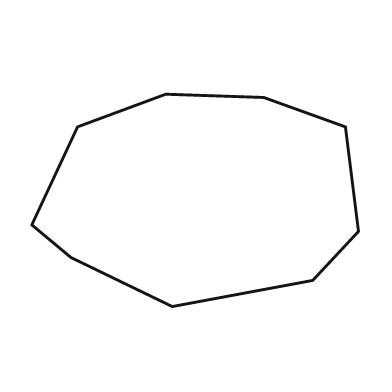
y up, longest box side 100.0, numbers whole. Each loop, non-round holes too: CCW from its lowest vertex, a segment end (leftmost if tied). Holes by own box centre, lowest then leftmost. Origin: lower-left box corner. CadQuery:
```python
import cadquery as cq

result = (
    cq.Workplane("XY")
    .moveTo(43.0, 0.0)
    .lineTo(86.0, 8.0)
    .lineTo(100.0, 23.0)
    .lineTo(96.0, 55.0)
    .lineTo(71.0, 64.0)
    .lineTo(41.0, 65.0)
    .lineTo(14.0, 55.0)
    .lineTo(0.0, 25.0)
    .lineTo(12.0, 15.0)
    .close()
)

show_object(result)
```